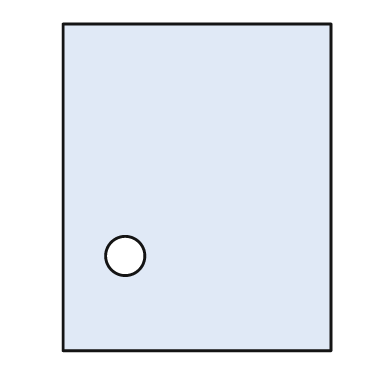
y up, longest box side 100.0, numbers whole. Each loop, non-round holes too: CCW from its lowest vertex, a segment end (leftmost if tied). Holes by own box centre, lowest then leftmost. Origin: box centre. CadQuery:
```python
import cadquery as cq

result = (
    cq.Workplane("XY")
    .moveTo(-41.0, -50.0)
    .lineTo(41.0, -50.0)
    .lineTo(41.0, 50.0)
    .lineTo(-41.0, 50.0)
    .close()
    .moveTo(-22.0, -21.0)
    .circle(6.0)
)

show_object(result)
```